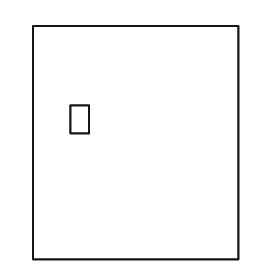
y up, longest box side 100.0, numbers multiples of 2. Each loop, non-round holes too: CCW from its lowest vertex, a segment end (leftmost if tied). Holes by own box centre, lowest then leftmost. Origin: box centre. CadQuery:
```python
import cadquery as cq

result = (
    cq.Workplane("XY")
    .moveTo(-44.0, -50.0)
    .lineTo(44.0, -50.0)
    .lineTo(44.0, 50.0)
    .lineTo(-44.0, 50.0)
    .close()
    .moveTo(-28.0, 4.0)
    .lineTo(-20.0, 4.0)
    .lineTo(-20.0, 16.0)
    .lineTo(-28.0, 16.0)
    .close()
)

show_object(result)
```